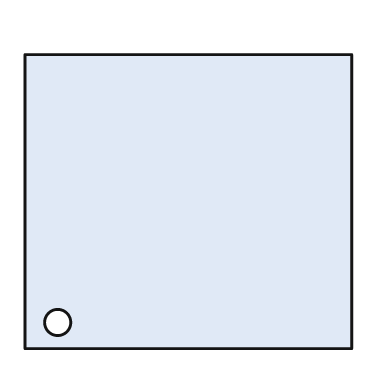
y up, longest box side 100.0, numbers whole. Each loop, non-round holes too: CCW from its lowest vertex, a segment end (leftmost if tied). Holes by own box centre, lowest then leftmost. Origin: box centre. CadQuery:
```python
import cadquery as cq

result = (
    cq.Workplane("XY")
    .moveTo(-50.0, -45.0)
    .lineTo(50.0, -45.0)
    .lineTo(50.0, 45.0)
    .lineTo(-50.0, 45.0)
    .close()
    .moveTo(-40.0, -37.0)
    .circle(4.0)
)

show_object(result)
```